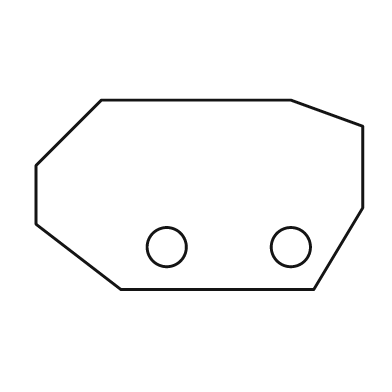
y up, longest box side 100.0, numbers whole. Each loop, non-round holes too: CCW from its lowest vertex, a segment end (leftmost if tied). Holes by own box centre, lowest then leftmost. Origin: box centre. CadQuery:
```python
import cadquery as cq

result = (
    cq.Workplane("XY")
    .moveTo(-24.0, -29.0)
    .lineTo(35.0, -29.0)
    .lineTo(50.0, -4.0)
    .lineTo(50.0, 21.0)
    .lineTo(28.0, 29.0)
    .lineTo(-30.0, 29.0)
    .lineTo(-50.0, 9.0)
    .lineTo(-50.0, -9.0)
    .close()
    .moveTo(-10.0, -16.0)
    .circle(6.0)
    .moveTo(28.0, -16.0)
    .circle(6.0)
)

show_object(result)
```